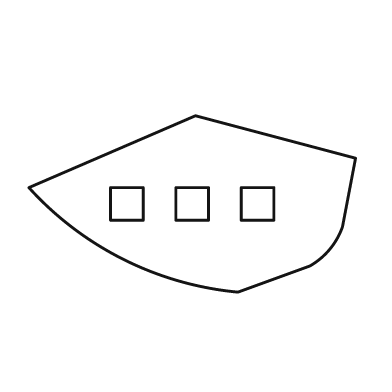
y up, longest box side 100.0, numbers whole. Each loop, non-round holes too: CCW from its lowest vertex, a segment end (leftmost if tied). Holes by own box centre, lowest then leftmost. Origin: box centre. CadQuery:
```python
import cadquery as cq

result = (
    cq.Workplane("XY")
    .moveTo(14.0, -27.0)
    .lineTo(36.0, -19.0)
    .threePointArc((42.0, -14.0), (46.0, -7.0))
    .lineTo(50.0, 14.0)
    .lineTo(1.0, 27.0)
    .lineTo(-50.0, 5.0)
    .threePointArc((-21.0, -17.0), (14.0, -27.0))
    .close()
    .moveTo(-25.0, -5.0)
    .lineTo(-15.0, -5.0)
    .lineTo(-15.0, 5.0)
    .lineTo(-25.0, 5.0)
    .close()
    .moveTo(-5.0, -5.0)
    .lineTo(5.0, -5.0)
    .lineTo(5.0, 5.0)
    .lineTo(-5.0, 5.0)
    .close()
    .moveTo(15.0, -5.0)
    .lineTo(25.0, -5.0)
    .lineTo(25.0, 5.0)
    .lineTo(15.0, 5.0)
    .close()
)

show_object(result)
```